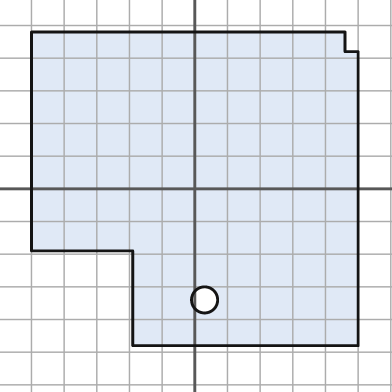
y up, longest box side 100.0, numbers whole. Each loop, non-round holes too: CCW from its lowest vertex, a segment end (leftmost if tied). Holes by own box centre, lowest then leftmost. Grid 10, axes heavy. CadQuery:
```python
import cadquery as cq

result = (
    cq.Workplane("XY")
    .moveTo(-19.0, -48.0)
    .lineTo(50.0, -48.0)
    .lineTo(50.0, 42.0)
    .lineTo(46.0, 42.0)
    .lineTo(46.0, 48.0)
    .lineTo(-50.0, 48.0)
    .lineTo(-50.0, -19.0)
    .lineTo(-19.0, -19.0)
    .close()
    .moveTo(3.0, -34.0)
    .circle(4.0)
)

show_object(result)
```